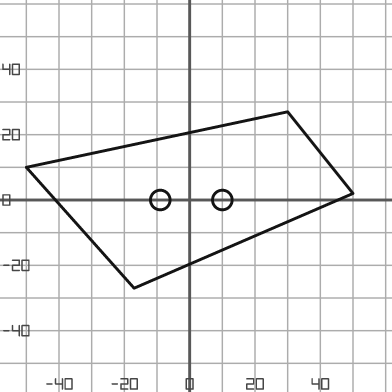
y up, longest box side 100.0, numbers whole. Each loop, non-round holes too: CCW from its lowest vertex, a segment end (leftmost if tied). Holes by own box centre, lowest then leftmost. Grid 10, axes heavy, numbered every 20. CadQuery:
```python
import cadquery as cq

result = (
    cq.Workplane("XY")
    .moveTo(-17.0, -27.0)
    .lineTo(50.0, 2.0)
    .lineTo(30.0, 27.0)
    .lineTo(-50.0, 10.0)
    .close()
    .moveTo(-9.0, 0.0)
    .circle(3.0)
    .moveTo(10.0, 0.0)
    .circle(3.0)
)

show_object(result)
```